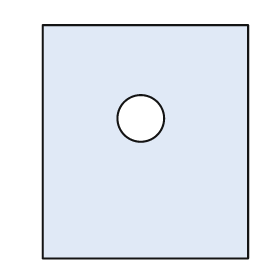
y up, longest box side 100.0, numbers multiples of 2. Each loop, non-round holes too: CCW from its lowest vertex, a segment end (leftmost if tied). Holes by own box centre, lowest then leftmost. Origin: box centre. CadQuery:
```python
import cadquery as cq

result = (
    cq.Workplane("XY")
    .moveTo(-44.0, -50.0)
    .lineTo(44.0, -50.0)
    .lineTo(44.0, 50.0)
    .lineTo(-44.0, 50.0)
    .close()
    .moveTo(-2.0, 10.0)
    .circle(10.0)
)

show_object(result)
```